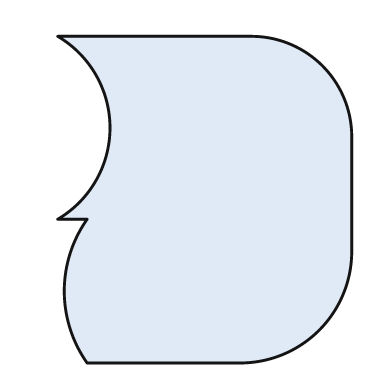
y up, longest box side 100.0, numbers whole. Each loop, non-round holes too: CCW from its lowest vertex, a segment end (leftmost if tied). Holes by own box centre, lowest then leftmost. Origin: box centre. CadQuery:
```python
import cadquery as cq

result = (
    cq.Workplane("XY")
    .moveTo(-36.0, -50.0)
    .lineTo(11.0, -50.0)
    .threePointArc((35.0, -40.0), (45.0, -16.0))
    .lineTo(45.0, 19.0)
    .threePointArc((36.0, 41.0), (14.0, 50.0))
    .lineTo(-45.0, 50.0)
    .threePointArc((-29.0, 22.0), (-45.0, -6.0))
    .lineTo(-36.0, -6.0)
    .threePointArc((-43.0, -28.0), (-36.0, -50.0))
    .close()
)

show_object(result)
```